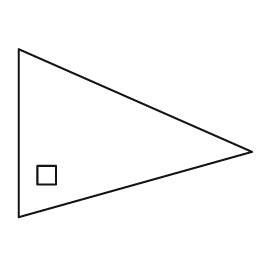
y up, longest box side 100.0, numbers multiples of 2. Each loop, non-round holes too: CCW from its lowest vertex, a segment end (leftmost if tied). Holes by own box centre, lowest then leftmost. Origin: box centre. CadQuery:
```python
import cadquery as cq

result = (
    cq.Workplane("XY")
    .moveTo(-50.0, -36.0)
    .lineTo(50.0, -8.0)
    .lineTo(-50.0, 36.0)
    .close()
    .moveTo(-42.0, -22.0)
    .lineTo(-34.0, -22.0)
    .lineTo(-34.0, -14.0)
    .lineTo(-42.0, -14.0)
    .close()
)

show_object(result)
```